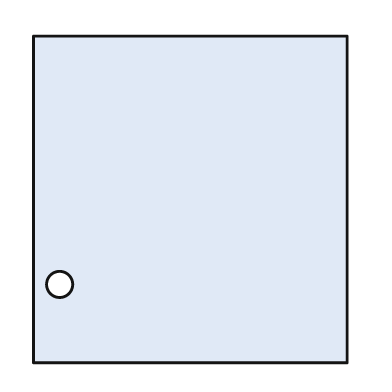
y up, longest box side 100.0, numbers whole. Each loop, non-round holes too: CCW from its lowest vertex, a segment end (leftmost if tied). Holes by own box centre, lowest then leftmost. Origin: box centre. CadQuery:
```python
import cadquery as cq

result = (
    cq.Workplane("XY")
    .moveTo(-48.0, -50.0)
    .lineTo(48.0, -50.0)
    .lineTo(48.0, 50.0)
    .lineTo(-48.0, 50.0)
    .close()
    .moveTo(-40.0, -26.0)
    .circle(4.0)
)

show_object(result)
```